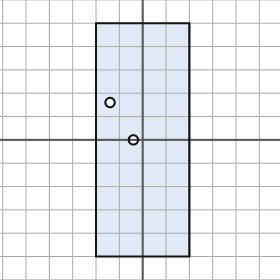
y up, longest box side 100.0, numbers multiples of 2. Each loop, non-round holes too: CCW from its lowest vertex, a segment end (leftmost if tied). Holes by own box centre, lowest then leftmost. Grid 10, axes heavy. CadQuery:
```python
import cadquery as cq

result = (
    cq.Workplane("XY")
    .moveTo(-20.0, -50.0)
    .lineTo(20.0, -50.0)
    .lineTo(20.0, 50.0)
    .lineTo(-20.0, 50.0)
    .close()
    .moveTo(-4.0, 0.0)
    .circle(2.0)
    .moveTo(-14.0, 16.0)
    .circle(2.0)
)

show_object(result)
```